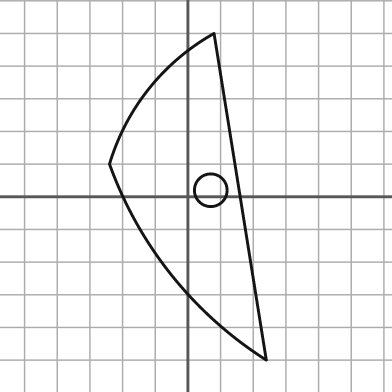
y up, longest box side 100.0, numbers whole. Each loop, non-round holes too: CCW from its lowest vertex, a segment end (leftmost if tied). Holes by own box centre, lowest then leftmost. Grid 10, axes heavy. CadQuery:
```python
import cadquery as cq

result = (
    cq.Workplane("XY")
    .moveTo(24.0, -50.0)
    .lineTo(8.0, 50.0)
    .threePointArc((-12.0, 33.0), (-24.0, 10.0))
    .threePointArc((-5.0, -24.0), (24.0, -50.0))
    .close()
    .moveTo(7.0, 2.0)
    .circle(5.0)
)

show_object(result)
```